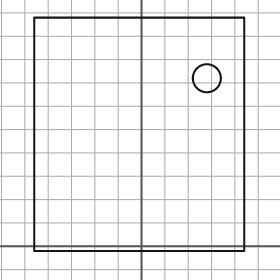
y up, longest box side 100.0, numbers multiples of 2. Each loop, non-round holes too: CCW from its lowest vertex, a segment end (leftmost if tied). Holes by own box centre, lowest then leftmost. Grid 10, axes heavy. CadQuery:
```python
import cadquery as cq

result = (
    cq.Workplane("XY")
    .moveTo(-46.0, -2.0)
    .lineTo(44.0, -2.0)
    .lineTo(44.0, 98.0)
    .lineTo(-46.0, 98.0)
    .close()
    .moveTo(28.0, 72.0)
    .circle(6.0)
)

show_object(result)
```